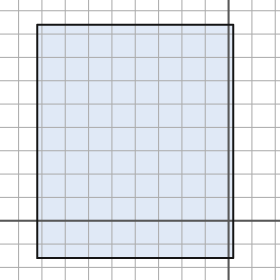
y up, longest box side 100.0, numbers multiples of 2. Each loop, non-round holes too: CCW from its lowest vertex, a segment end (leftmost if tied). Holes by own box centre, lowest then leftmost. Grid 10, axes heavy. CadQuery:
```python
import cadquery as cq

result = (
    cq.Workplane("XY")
    .moveTo(-82.0, -16.0)
    .lineTo(2.0, -16.0)
    .lineTo(2.0, 84.0)
    .lineTo(-82.0, 84.0)
    .close()
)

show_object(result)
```